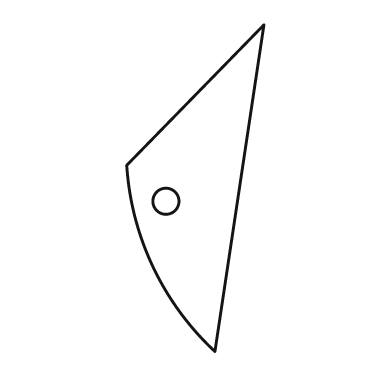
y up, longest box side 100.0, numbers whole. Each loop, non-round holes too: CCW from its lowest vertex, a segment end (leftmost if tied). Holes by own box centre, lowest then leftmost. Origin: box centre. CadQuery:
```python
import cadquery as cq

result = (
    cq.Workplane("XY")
    .moveTo(6.0, -50.0)
    .lineTo(21.0, 50.0)
    .lineTo(-21.0, 7.0)
    .threePointArc((-13.0, -24.0), (6.0, -50.0))
    .close()
    .moveTo(-9.0, -4.0)
    .circle(4.0)
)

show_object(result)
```